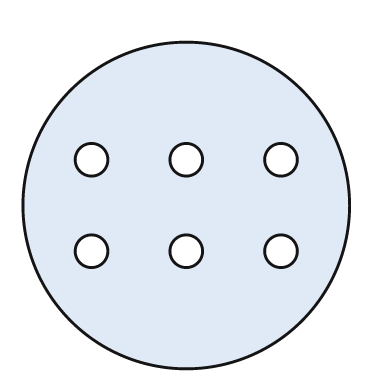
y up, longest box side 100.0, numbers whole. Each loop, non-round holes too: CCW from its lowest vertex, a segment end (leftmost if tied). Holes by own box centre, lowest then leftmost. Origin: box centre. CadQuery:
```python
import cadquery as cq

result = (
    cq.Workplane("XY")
    .moveTo(0.0, 0.0)
    .circle(50.0)
    .moveTo(-29.0, -14.0)
    .circle(5.0)
    .moveTo(0.0, -14.0)
    .circle(5.0)
    .moveTo(29.0, -14.0)
    .circle(5.0)
    .moveTo(-29.0, 14.0)
    .circle(5.0)
    .moveTo(0.0, 14.0)
    .circle(5.0)
    .moveTo(29.0, 14.0)
    .circle(5.0)
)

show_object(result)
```